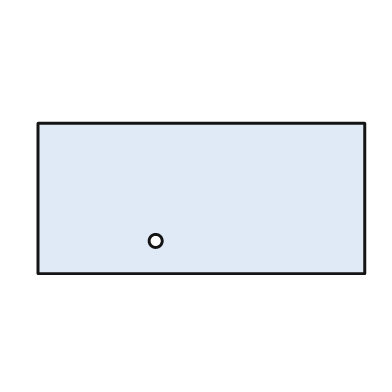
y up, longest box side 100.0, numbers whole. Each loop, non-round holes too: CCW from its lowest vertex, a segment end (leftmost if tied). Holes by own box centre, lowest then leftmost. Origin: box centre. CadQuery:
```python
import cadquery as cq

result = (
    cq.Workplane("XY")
    .moveTo(-50.0, -23.0)
    .lineTo(50.0, -23.0)
    .lineTo(50.0, 23.0)
    .lineTo(-50.0, 23.0)
    .close()
    .moveTo(-14.0, -13.0)
    .circle(2.0)
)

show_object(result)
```